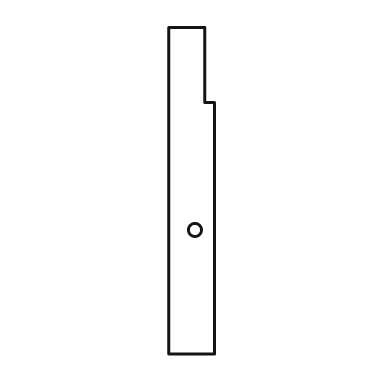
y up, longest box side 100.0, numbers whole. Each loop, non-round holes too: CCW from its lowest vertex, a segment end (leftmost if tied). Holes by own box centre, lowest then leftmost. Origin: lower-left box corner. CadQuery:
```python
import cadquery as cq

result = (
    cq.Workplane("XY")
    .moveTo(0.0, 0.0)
    .lineTo(14.0, 0.0)
    .lineTo(14.0, 77.0)
    .lineTo(11.0, 77.0)
    .lineTo(11.0, 100.0)
    .lineTo(0.0, 100.0)
    .close()
    .moveTo(8.0, 38.0)
    .circle(2.0)
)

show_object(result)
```